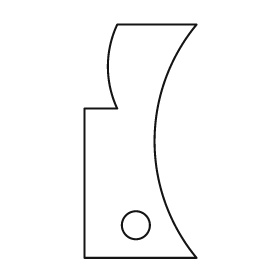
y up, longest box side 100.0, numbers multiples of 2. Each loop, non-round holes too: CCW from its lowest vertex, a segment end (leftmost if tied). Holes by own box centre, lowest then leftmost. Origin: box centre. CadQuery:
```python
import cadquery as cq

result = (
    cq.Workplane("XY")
    .moveTo(-24.0, -50.0)
    .lineTo(24.0, -50.0)
    .threePointArc((6.0, 0.0), (24.0, 50.0))
    .lineTo(-10.0, 50.0)
    .threePointArc((-14.0, 32.0), (-10.0, 14.0))
    .lineTo(-24.0, 14.0)
    .close()
    .moveTo(-2.0, -36.0)
    .circle(6.0)
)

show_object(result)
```